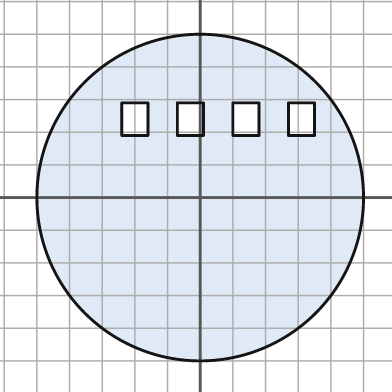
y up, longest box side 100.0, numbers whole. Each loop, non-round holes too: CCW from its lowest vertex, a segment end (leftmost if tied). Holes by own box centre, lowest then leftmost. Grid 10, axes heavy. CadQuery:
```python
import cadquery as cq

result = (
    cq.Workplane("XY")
    .moveTo(0.0, 0.0)
    .circle(50.0)
    .moveTo(-24.0, 19.0)
    .lineTo(-16.0, 19.0)
    .lineTo(-16.0, 29.0)
    .lineTo(-24.0, 29.0)
    .close()
    .moveTo(-7.0, 19.0)
    .lineTo(1.0, 19.0)
    .lineTo(1.0, 29.0)
    .lineTo(-7.0, 29.0)
    .close()
    .moveTo(10.0, 19.0)
    .lineTo(18.0, 19.0)
    .lineTo(18.0, 29.0)
    .lineTo(10.0, 29.0)
    .close()
    .moveTo(27.0, 19.0)
    .lineTo(35.0, 19.0)
    .lineTo(35.0, 29.0)
    .lineTo(27.0, 29.0)
    .close()
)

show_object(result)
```